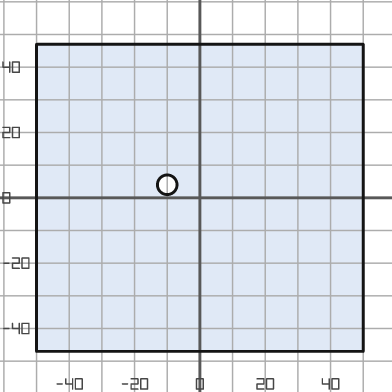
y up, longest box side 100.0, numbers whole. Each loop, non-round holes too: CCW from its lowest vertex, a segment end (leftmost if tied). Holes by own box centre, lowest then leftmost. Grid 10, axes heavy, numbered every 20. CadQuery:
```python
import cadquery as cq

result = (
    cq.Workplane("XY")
    .moveTo(-50.0, -47.0)
    .lineTo(50.0, -47.0)
    .lineTo(50.0, 47.0)
    .lineTo(-50.0, 47.0)
    .close()
    .moveTo(-10.0, 4.0)
    .circle(3.0)
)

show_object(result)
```